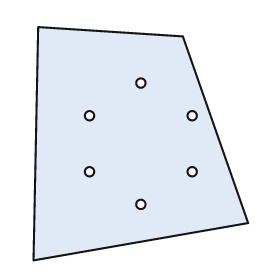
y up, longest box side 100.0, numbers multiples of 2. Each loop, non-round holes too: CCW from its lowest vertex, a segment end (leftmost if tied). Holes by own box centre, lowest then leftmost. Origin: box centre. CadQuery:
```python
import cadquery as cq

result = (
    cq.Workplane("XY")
    .moveTo(-46.0, -50.0)
    .lineTo(46.0, -34.0)
    .lineTo(18.0, 46.0)
    .lineTo(-44.0, 50.0)
    .close()
    .moveTo(0.0, -26.0)
    .circle(2.0)
    .moveTo(-22.0, -12.0)
    .circle(2.0)
    .moveTo(22.0, -12.0)
    .circle(2.0)
    .moveTo(-22.0, 12.0)
    .circle(2.0)
    .moveTo(22.0, 12.0)
    .circle(2.0)
    .moveTo(0.0, 26.0)
    .circle(2.0)
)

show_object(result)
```